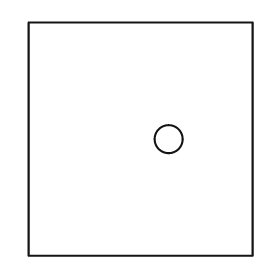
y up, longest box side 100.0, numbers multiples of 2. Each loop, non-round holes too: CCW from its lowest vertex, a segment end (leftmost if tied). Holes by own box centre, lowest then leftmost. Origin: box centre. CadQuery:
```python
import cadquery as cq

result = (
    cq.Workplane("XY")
    .moveTo(-48.0, -50.0)
    .lineTo(48.0, -50.0)
    .lineTo(48.0, 50.0)
    .lineTo(-48.0, 50.0)
    .close()
    .moveTo(12.0, 0.0)
    .circle(6.0)
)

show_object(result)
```